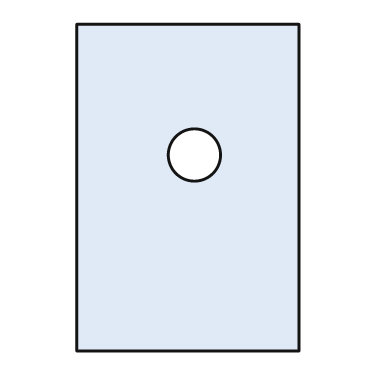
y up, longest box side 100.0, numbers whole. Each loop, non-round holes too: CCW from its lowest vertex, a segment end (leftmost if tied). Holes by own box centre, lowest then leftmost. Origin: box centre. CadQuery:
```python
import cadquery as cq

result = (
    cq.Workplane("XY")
    .moveTo(-34.0, -50.0)
    .lineTo(34.0, -50.0)
    .lineTo(34.0, 50.0)
    .lineTo(-34.0, 50.0)
    .close()
    .moveTo(2.0, 10.0)
    .circle(8.0)
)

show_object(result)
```